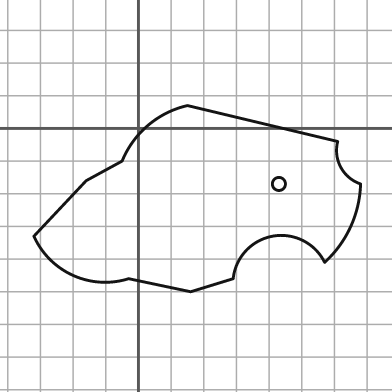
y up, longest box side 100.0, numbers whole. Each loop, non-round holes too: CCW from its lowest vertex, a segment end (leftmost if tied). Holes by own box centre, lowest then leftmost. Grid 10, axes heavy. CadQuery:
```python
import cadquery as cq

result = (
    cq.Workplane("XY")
    .moveTo(16.0, -50.0)
    .lineTo(29.0, -46.0)
    .threePointArc((41.0, -33.0), (57.0, -41.0))
    .threePointArc((65.0, -30.0), (68.0, -17.0))
    .threePointArc((62.0, -12.0), (61.0, -4.0))
    .lineTo(15.0, 7.0)
    .threePointArc((3.0, 1.0), (-5.0, -10.0))
    .lineTo(-16.0, -16.0)
    .lineTo(-32.0, -33.0)
    .threePointArc((-20.0, -45.0), (-3.0, -46.0))
    .close()
    .moveTo(43.0, -17.0)
    .circle(2.0)
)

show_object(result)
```